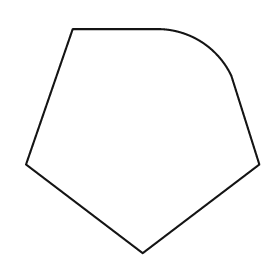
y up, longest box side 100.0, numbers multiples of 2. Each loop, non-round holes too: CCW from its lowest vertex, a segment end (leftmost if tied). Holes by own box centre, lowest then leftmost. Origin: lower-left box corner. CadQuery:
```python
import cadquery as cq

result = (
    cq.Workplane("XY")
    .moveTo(50.0, 0.0)
    .lineTo(100.0, 38.0)
    .lineTo(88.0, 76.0)
    .threePointArc((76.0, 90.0), (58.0, 96.0))
    .lineTo(20.0, 96.0)
    .lineTo(0.0, 38.0)
    .close()
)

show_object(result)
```